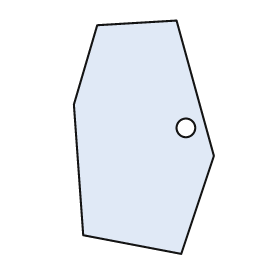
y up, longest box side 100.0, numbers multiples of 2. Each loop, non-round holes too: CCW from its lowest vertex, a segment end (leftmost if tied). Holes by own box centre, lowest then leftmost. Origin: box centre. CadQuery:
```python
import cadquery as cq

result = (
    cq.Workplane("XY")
    .moveTo(16.0, -50.0)
    .lineTo(30.0, -8.0)
    .lineTo(14.0, 50.0)
    .lineTo(-20.0, 48.0)
    .lineTo(-30.0, 14.0)
    .lineTo(-26.0, -42.0)
    .close()
    .moveTo(18.0, 4.0)
    .circle(4.0)
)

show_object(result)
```